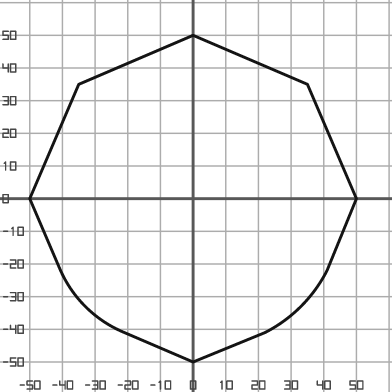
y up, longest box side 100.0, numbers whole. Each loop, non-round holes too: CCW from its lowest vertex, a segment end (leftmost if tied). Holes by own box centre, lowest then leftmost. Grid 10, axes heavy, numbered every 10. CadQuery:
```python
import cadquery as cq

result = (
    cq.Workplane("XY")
    .moveTo(0.0, -50.0)
    .lineTo(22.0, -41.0)
    .threePointArc((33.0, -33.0), (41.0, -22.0))
    .lineTo(50.0, 0.0)
    .lineTo(35.0, 35.0)
    .lineTo(0.0, 50.0)
    .lineTo(-35.0, 35.0)
    .lineTo(-50.0, 0.0)
    .lineTo(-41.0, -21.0)
    .threePointArc((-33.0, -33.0), (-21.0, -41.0))
    .close()
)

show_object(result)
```